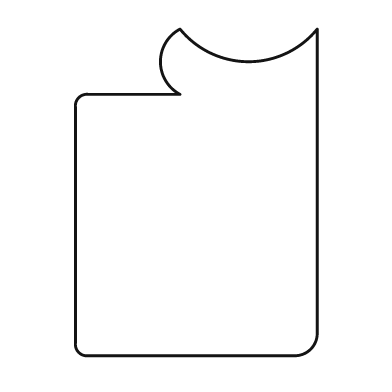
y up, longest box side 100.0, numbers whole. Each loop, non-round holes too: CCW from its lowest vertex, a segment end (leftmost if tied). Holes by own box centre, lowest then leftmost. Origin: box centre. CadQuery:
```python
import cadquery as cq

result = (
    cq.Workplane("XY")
    .moveTo(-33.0, -50.0)
    .lineTo(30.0, -50.0)
    .threePointArc((35.0, -48.0), (37.0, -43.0))
    .lineTo(37.0, 50.0)
    .threePointArc((16.0, 40.0), (-5.0, 50.0))
    .threePointArc((-11.0, 40.0), (-5.0, 30.0))
    .lineTo(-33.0, 30.0)
    .threePointArc((-36.0, 29.0), (-37.0, 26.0))
    .lineTo(-37.0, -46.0)
    .threePointArc((-36.0, -49.0), (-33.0, -50.0))
    .close()
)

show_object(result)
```